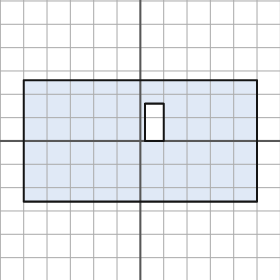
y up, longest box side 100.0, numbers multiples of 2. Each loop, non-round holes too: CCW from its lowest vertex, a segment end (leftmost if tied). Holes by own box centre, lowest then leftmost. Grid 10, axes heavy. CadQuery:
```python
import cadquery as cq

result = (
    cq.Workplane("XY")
    .moveTo(-50.0, -26.0)
    .lineTo(50.0, -26.0)
    .lineTo(50.0, 26.0)
    .lineTo(-50.0, 26.0)
    .close()
    .moveTo(2.0, 0.0)
    .lineTo(10.0, 0.0)
    .lineTo(10.0, 16.0)
    .lineTo(2.0, 16.0)
    .close()
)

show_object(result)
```